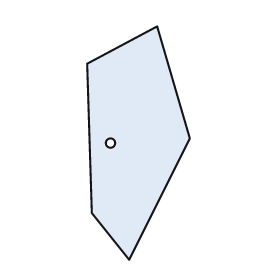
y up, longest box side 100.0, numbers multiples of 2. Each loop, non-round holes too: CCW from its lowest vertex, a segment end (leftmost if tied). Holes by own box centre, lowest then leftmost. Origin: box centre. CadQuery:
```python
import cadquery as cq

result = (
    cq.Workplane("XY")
    .moveTo(-4.0, -50.0)
    .lineTo(22.0, 2.0)
    .lineTo(8.0, 50.0)
    .lineTo(-22.0, 34.0)
    .lineTo(-20.0, -30.0)
    .close()
    .moveTo(-12.0, 0.0)
    .circle(2.0)
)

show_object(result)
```